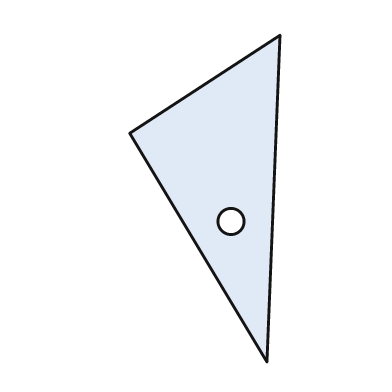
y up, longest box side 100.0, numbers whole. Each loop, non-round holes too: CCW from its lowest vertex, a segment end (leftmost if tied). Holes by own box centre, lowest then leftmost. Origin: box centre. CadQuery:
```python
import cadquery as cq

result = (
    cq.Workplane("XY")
    .moveTo(19.0, -50.0)
    .lineTo(23.0, 50.0)
    .lineTo(-23.0, 20.0)
    .close()
    .moveTo(8.0, -7.0)
    .circle(4.0)
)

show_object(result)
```